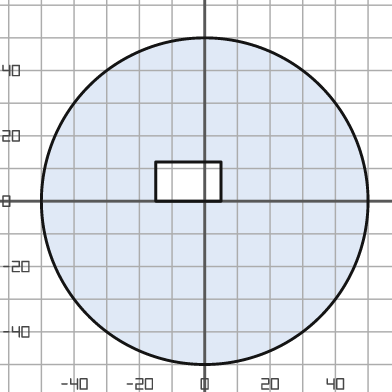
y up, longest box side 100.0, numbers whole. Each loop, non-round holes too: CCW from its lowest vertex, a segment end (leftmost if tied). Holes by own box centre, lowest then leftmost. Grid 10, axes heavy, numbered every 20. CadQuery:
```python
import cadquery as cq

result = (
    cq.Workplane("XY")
    .moveTo(0.0, 0.0)
    .circle(50.0)
    .moveTo(-15.0, 0.0)
    .lineTo(5.0, 0.0)
    .lineTo(5.0, 12.0)
    .lineTo(-15.0, 12.0)
    .close()
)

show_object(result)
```